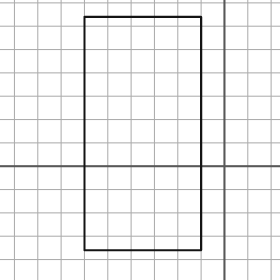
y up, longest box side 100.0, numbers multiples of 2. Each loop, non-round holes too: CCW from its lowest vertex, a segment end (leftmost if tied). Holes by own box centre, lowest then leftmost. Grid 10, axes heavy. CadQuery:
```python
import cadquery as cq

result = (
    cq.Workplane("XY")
    .moveTo(-60.0, -36.0)
    .lineTo(-10.0, -36.0)
    .lineTo(-10.0, 64.0)
    .lineTo(-60.0, 64.0)
    .close()
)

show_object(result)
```